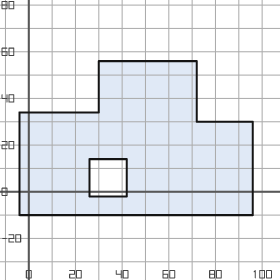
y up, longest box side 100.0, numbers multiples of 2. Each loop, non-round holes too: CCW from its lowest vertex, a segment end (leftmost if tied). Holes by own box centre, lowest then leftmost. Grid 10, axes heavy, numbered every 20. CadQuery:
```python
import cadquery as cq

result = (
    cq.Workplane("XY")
    .moveTo(-4.0, -10.0)
    .lineTo(96.0, -10.0)
    .lineTo(96.0, 30.0)
    .lineTo(72.0, 30.0)
    .lineTo(72.0, 56.0)
    .lineTo(30.0, 56.0)
    .lineTo(30.0, 34.0)
    .lineTo(-4.0, 34.0)
    .close()
    .moveTo(26.0, -2.0)
    .lineTo(42.0, -2.0)
    .lineTo(42.0, 14.0)
    .lineTo(26.0, 14.0)
    .close()
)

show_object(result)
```